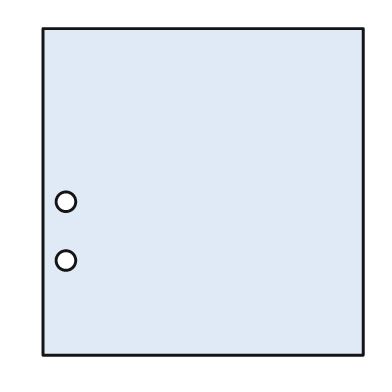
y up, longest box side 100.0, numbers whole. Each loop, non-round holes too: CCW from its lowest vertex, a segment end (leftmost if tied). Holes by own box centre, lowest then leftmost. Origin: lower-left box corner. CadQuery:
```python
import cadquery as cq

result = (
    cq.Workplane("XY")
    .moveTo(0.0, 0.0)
    .lineTo(98.0, 0.0)
    .lineTo(98.0, 100.0)
    .lineTo(0.0, 100.0)
    .close()
    .moveTo(7.0, 29.0)
    .circle(3.0)
    .moveTo(7.0, 47.0)
    .circle(3.0)
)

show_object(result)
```